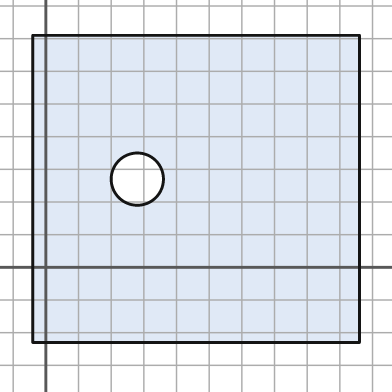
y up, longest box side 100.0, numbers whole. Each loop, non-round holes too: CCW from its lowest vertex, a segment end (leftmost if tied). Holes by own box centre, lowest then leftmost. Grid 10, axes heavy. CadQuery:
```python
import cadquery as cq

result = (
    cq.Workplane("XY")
    .moveTo(-4.0, -23.0)
    .lineTo(96.0, -23.0)
    .lineTo(96.0, 71.0)
    .lineTo(-4.0, 71.0)
    .close()
    .moveTo(28.0, 27.0)
    .circle(8.0)
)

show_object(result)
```